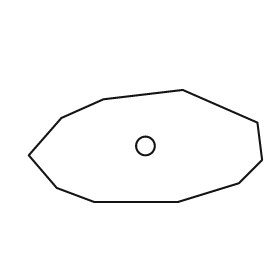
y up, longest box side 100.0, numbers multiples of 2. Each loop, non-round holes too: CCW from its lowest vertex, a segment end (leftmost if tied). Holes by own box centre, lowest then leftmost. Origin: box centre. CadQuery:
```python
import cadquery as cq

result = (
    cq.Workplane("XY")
    .moveTo(-22.0, -24.0)
    .lineTo(14.0, -24.0)
    .lineTo(40.0, -16.0)
    .lineTo(50.0, -6.0)
    .lineTo(48.0, 10.0)
    .lineTo(16.0, 24.0)
    .lineTo(-18.0, 20.0)
    .lineTo(-36.0, 12.0)
    .lineTo(-50.0, -4.0)
    .lineTo(-38.0, -18.0)
    .close()
    .moveTo(0.0, 0.0)
    .circle(4.0)
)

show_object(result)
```